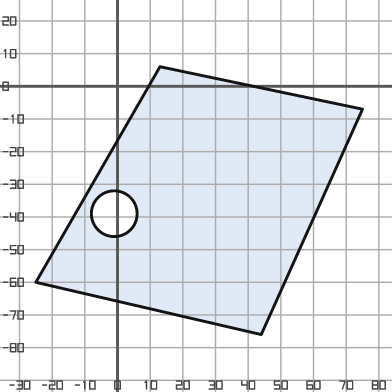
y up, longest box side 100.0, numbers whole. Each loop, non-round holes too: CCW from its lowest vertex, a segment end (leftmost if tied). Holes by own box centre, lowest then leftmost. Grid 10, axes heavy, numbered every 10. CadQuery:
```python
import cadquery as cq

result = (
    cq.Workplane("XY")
    .moveTo(44.0, -76.0)
    .lineTo(75.0, -7.0)
    .lineTo(13.0, 6.0)
    .lineTo(-25.0, -60.0)
    .close()
    .moveTo(-1.0, -39.0)
    .circle(7.0)
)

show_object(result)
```